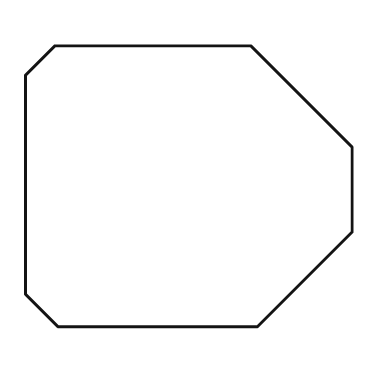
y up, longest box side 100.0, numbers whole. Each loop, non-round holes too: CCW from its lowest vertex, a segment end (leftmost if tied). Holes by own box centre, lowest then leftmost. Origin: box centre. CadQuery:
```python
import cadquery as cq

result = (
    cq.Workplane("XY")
    .moveTo(-40.0, -43.0)
    .lineTo(21.0, -43.0)
    .lineTo(50.0, -14.0)
    .lineTo(50.0, 12.0)
    .lineTo(19.0, 43.0)
    .lineTo(-41.0, 43.0)
    .lineTo(-50.0, 34.0)
    .lineTo(-50.0, -33.0)
    .close()
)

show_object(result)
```